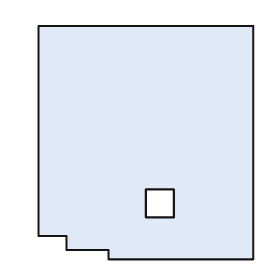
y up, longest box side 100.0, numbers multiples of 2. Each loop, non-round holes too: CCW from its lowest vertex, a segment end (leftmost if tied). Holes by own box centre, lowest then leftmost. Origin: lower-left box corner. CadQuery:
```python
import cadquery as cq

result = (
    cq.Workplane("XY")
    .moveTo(30.0, 0.0)
    .lineTo(92.0, 0.0)
    .lineTo(92.0, 100.0)
    .lineTo(0.0, 100.0)
    .lineTo(0.0, 10.0)
    .lineTo(12.0, 10.0)
    .lineTo(12.0, 4.0)
    .lineTo(30.0, 4.0)
    .close()
    .moveTo(46.0, 18.0)
    .lineTo(58.0, 18.0)
    .lineTo(58.0, 30.0)
    .lineTo(46.0, 30.0)
    .close()
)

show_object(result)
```